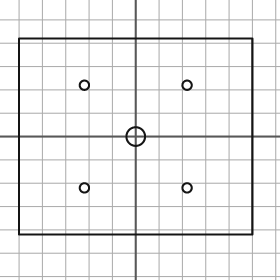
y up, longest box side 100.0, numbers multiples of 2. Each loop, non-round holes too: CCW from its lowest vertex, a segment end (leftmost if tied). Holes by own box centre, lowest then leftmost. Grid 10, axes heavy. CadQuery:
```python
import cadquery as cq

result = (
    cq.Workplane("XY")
    .moveTo(-50.0, -42.0)
    .lineTo(50.0, -42.0)
    .lineTo(50.0, 42.0)
    .lineTo(-50.0, 42.0)
    .close()
    .moveTo(-22.0, -22.0)
    .circle(2.0)
    .moveTo(22.0, -22.0)
    .circle(2.0)
    .moveTo(0.0, 0.0)
    .circle(4.0)
    .moveTo(-22.0, 22.0)
    .circle(2.0)
    .moveTo(22.0, 22.0)
    .circle(2.0)
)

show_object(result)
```